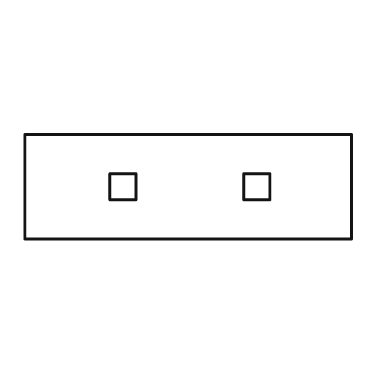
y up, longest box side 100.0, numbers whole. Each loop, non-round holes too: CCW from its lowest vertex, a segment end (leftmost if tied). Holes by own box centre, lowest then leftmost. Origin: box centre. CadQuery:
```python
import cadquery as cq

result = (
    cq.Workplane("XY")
    .moveTo(-50.0, -16.0)
    .lineTo(50.0, -16.0)
    .lineTo(50.0, 16.0)
    .lineTo(-50.0, 16.0)
    .close()
    .moveTo(-24.0, -4.0)
    .lineTo(-16.0, -4.0)
    .lineTo(-16.0, 4.0)
    .lineTo(-24.0, 4.0)
    .close()
    .moveTo(17.0, -4.0)
    .lineTo(25.0, -4.0)
    .lineTo(25.0, 4.0)
    .lineTo(17.0, 4.0)
    .close()
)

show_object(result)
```